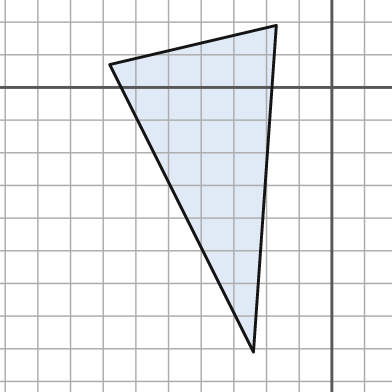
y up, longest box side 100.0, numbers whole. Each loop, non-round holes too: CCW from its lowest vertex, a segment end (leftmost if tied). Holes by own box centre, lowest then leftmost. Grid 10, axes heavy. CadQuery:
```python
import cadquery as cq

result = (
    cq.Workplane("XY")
    .moveTo(-24.0, -81.0)
    .lineTo(-17.0, 19.0)
    .lineTo(-68.0, 7.0)
    .close()
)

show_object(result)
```